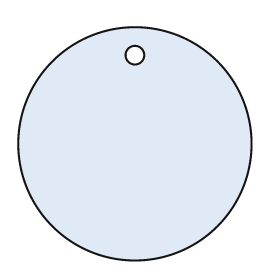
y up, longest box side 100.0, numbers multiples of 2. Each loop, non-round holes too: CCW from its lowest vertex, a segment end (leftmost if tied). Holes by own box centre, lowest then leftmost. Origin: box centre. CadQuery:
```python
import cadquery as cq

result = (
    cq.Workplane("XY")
    .moveTo(0.0, 0.0)
    .circle(50.0)
    .moveTo(0.0, 38.0)
    .circle(4.0)
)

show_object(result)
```